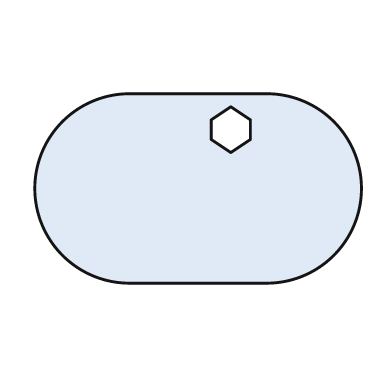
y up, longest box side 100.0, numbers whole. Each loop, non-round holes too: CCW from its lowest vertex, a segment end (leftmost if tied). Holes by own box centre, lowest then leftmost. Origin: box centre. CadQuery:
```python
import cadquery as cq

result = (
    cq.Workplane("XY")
    .moveTo(-21.0, -29.0)
    .lineTo(21.0, -29.0)
    .threePointArc((50.0, 0.0), (21.0, 29.0))
    .lineTo(-21.0, 29.0)
    .threePointArc((-50.0, 0.0), (-21.0, -29.0))
    .close()
    .moveTo(10.0, 11.0)
    .lineTo(16.0, 15.0)
    .lineTo(16.0, 21.0)
    .lineTo(10.0, 25.0)
    .lineTo(4.0, 21.0)
    .lineTo(4.0, 15.0)
    .close()
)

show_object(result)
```